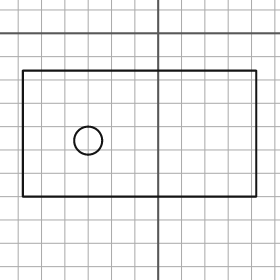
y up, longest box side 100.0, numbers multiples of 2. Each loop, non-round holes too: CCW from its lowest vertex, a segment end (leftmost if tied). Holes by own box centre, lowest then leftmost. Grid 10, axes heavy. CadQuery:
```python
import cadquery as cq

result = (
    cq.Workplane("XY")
    .moveTo(-58.0, -70.0)
    .lineTo(42.0, -70.0)
    .lineTo(42.0, -16.0)
    .lineTo(-58.0, -16.0)
    .close()
    .moveTo(-30.0, -46.0)
    .circle(6.0)
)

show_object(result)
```